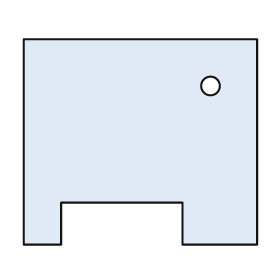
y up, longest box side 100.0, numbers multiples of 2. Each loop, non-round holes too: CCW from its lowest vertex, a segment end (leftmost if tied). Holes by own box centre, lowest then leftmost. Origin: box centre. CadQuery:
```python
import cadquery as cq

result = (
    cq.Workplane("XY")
    .moveTo(-50.0, -44.0)
    .lineTo(-34.0, -44.0)
    .lineTo(-34.0, -26.0)
    .lineTo(18.0, -26.0)
    .lineTo(18.0, -44.0)
    .lineTo(50.0, -44.0)
    .lineTo(50.0, 44.0)
    .lineTo(-50.0, 44.0)
    .close()
    .moveTo(30.0, 24.0)
    .circle(4.0)
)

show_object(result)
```